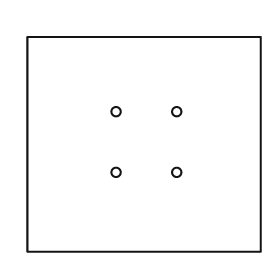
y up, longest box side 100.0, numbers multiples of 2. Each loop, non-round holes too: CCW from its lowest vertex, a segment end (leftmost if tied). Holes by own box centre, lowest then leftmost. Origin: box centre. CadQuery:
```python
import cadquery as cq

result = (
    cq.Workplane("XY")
    .moveTo(-50.0, -46.0)
    .lineTo(50.0, -46.0)
    .lineTo(50.0, 46.0)
    .lineTo(-50.0, 46.0)
    .close()
    .moveTo(-12.0, -12.0)
    .circle(2.0)
    .moveTo(14.0, -12.0)
    .circle(2.0)
    .moveTo(-12.0, 14.0)
    .circle(2.0)
    .moveTo(14.0, 14.0)
    .circle(2.0)
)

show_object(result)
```